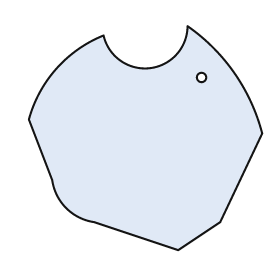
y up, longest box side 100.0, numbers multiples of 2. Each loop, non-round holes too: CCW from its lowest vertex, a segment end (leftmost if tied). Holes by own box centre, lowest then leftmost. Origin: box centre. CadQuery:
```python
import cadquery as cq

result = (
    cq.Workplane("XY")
    .moveTo(14.0, -48.0)
    .lineTo(32.0, -36.0)
    .lineTo(50.0, 2.0)
    .threePointArc((38.0, 28.0), (18.0, 48.0))
    .threePointArc((2.0, 30.0), (-18.0, 44.0))
    .threePointArc((-38.0, 30.0), (-50.0, 8.0))
    .lineTo(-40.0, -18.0)
    .threePointArc((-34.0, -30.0), (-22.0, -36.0))
    .close()
    .moveTo(24.0, 26.0)
    .circle(2.0)
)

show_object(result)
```